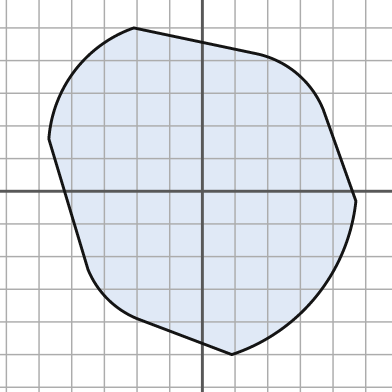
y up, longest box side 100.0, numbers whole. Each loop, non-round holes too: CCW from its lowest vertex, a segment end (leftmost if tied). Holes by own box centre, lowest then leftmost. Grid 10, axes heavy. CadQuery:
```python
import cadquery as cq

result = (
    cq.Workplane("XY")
    .moveTo(9.0, -50.0)
    .threePointArc((35.0, -32.0), (47.0, -3.0))
    .lineTo(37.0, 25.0)
    .threePointArc((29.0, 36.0), (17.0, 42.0))
    .lineTo(-21.0, 50.0)
    .threePointArc((-39.0, 37.0), (-47.0, 16.0))
    .lineTo(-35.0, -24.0)
    .threePointArc((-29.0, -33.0), (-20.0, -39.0))
    .close()
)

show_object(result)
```